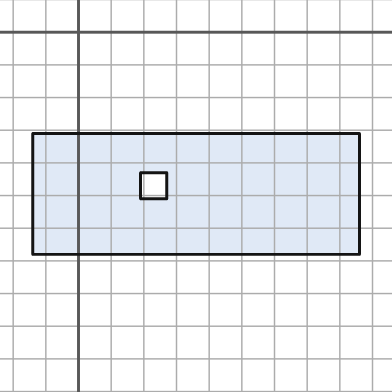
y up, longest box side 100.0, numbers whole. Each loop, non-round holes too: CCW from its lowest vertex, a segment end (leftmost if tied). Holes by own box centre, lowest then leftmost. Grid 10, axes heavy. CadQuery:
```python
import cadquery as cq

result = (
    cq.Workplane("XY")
    .moveTo(-14.0, -68.0)
    .lineTo(86.0, -68.0)
    .lineTo(86.0, -31.0)
    .lineTo(-14.0, -31.0)
    .close()
    .moveTo(19.0, -51.0)
    .lineTo(27.0, -51.0)
    .lineTo(27.0, -43.0)
    .lineTo(19.0, -43.0)
    .close()
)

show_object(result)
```